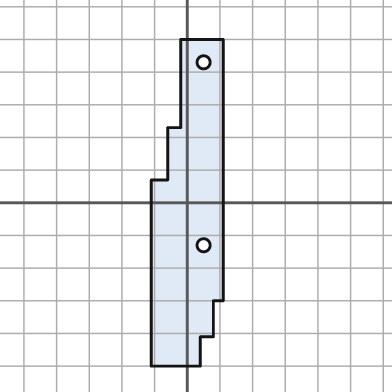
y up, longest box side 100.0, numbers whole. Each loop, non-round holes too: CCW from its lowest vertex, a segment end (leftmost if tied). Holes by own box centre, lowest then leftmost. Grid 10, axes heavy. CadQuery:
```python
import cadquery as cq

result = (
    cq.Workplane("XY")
    .moveTo(-11.0, -50.0)
    .lineTo(4.0, -50.0)
    .lineTo(4.0, -41.0)
    .lineTo(8.0, -41.0)
    .lineTo(8.0, -30.0)
    .lineTo(11.0, -30.0)
    .lineTo(11.0, 50.0)
    .lineTo(-2.0, 50.0)
    .lineTo(-2.0, 23.0)
    .lineTo(-6.0, 23.0)
    .lineTo(-6.0, 7.0)
    .lineTo(-11.0, 7.0)
    .close()
    .moveTo(5.0, -13.0)
    .circle(2.0)
    .moveTo(5.0, 43.0)
    .circle(2.0)
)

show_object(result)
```